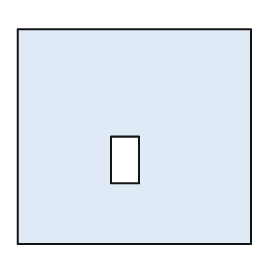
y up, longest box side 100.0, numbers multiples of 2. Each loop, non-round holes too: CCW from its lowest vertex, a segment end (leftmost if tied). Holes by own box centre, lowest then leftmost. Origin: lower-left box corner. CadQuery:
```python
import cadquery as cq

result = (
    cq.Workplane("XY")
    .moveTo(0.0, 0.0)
    .lineTo(100.0, 0.0)
    .lineTo(100.0, 92.0)
    .lineTo(0.0, 92.0)
    .close()
    .moveTo(40.0, 26.0)
    .lineTo(52.0, 26.0)
    .lineTo(52.0, 46.0)
    .lineTo(40.0, 46.0)
    .close()
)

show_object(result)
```